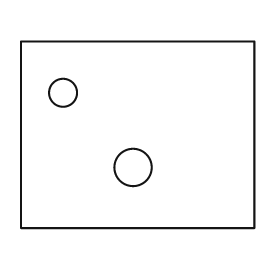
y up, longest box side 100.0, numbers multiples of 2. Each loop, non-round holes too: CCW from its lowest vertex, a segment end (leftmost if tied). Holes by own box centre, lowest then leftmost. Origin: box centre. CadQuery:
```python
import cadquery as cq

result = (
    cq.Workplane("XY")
    .moveTo(-50.0, -40.0)
    .lineTo(50.0, -40.0)
    .lineTo(50.0, 40.0)
    .lineTo(-50.0, 40.0)
    .close()
    .moveTo(-2.0, -14.0)
    .circle(8.0)
    .moveTo(-32.0, 18.0)
    .circle(6.0)
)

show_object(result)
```